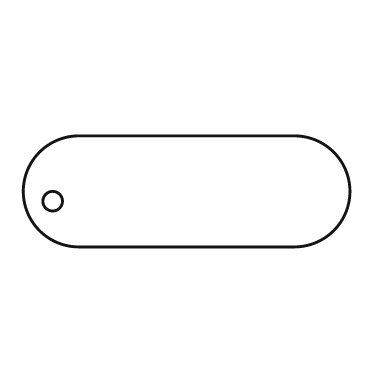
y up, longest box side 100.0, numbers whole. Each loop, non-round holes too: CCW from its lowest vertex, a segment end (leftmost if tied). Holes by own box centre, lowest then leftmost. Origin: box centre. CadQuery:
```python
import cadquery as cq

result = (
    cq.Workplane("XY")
    .moveTo(-33.0, -17.0)
    .lineTo(33.0, -17.0)
    .threePointArc((50.0, 0.0), (33.0, 17.0))
    .lineTo(-33.0, 17.0)
    .threePointArc((-50.0, 0.0), (-33.0, -17.0))
    .close()
    .moveTo(-41.0, -3.0)
    .circle(3.0)
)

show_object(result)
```